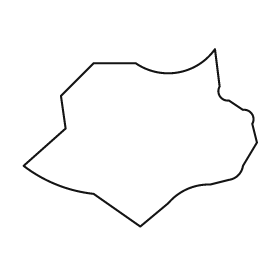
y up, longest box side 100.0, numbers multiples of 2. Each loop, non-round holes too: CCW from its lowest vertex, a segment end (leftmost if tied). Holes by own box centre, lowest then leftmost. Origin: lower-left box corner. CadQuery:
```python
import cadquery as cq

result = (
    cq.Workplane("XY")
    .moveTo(50.0, 0.0)
    .lineTo(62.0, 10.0)
    .threePointArc((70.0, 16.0), (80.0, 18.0))
    .lineTo(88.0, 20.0)
    .threePointArc((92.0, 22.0), (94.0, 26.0))
    .lineTo(100.0, 36.0)
    .lineTo(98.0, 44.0)
    .threePointArc((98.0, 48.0), (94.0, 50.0))
    .lineTo(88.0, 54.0)
    .threePointArc((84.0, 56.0), (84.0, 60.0))
    .lineTo(82.0, 76.0)
    .threePointArc((66.0, 66.0), (48.0, 70.0))
    .lineTo(30.0, 70.0)
    .lineTo(16.0, 56.0)
    .lineTo(18.0, 42.0)
    .lineTo(0.0, 26.0)
    .threePointArc((14.0, 18.0), (30.0, 14.0))
    .close()
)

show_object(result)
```